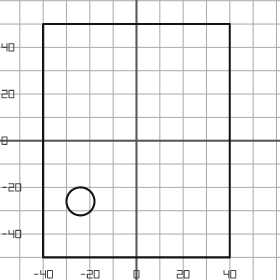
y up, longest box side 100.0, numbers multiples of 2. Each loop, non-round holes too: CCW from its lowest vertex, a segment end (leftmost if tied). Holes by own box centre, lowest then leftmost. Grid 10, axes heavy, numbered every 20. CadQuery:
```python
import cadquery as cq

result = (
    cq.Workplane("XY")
    .moveTo(-40.0, -50.0)
    .lineTo(40.0, -50.0)
    .lineTo(40.0, 50.0)
    .lineTo(-40.0, 50.0)
    .close()
    .moveTo(-24.0, -26.0)
    .circle(6.0)
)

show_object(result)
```